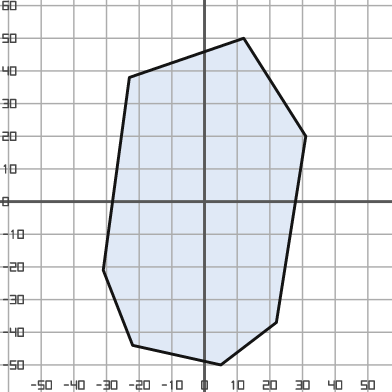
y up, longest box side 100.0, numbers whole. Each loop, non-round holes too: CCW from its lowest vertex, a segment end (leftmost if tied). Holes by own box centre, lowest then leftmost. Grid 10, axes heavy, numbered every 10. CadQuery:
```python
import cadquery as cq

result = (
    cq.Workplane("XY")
    .moveTo(5.0, -50.0)
    .lineTo(22.0, -37.0)
    .lineTo(31.0, 20.0)
    .lineTo(12.0, 50.0)
    .lineTo(-23.0, 38.0)
    .lineTo(-31.0, -21.0)
    .lineTo(-22.0, -44.0)
    .close()
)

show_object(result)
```